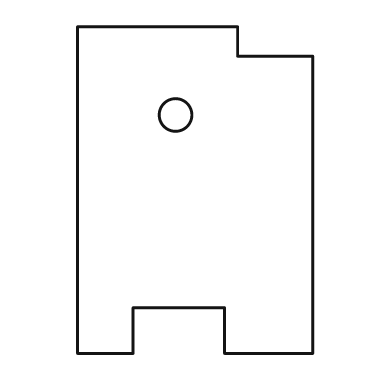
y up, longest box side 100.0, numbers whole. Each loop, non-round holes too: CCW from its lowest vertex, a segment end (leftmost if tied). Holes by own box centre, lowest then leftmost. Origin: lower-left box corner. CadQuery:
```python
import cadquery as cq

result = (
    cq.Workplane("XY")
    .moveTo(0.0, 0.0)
    .lineTo(17.0, 0.0)
    .lineTo(17.0, 14.0)
    .lineTo(45.0, 14.0)
    .lineTo(45.0, 0.0)
    .lineTo(72.0, 0.0)
    .lineTo(72.0, 91.0)
    .lineTo(49.0, 91.0)
    .lineTo(49.0, 100.0)
    .lineTo(0.0, 100.0)
    .close()
    .moveTo(30.0, 73.0)
    .circle(5.0)
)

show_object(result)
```